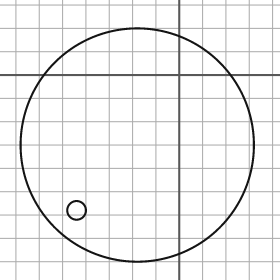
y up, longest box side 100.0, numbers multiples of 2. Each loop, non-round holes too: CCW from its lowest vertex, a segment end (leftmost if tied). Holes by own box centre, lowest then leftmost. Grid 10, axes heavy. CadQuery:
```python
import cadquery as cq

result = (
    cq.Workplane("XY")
    .moveTo(-18.0, -30.0)
    .circle(50.0)
    .moveTo(-44.0, -58.0)
    .circle(4.0)
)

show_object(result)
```